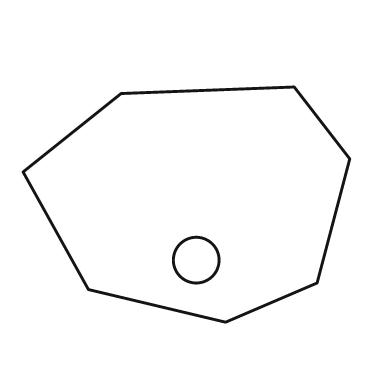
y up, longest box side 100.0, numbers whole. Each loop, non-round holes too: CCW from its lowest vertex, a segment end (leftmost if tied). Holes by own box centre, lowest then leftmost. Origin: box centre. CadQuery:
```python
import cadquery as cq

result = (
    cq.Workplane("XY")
    .moveTo(12.0, -36.0)
    .lineTo(40.0, -24.0)
    .lineTo(50.0, 14.0)
    .lineTo(33.0, 36.0)
    .lineTo(-20.0, 34.0)
    .lineTo(-50.0, 10.0)
    .lineTo(-30.0, -26.0)
    .close()
    .moveTo(3.0, -17.0)
    .circle(7.0)
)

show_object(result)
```